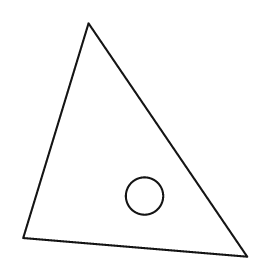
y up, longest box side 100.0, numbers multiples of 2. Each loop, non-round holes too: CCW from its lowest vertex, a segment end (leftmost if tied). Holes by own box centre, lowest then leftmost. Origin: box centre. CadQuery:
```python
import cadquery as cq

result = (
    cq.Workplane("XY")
    .moveTo(48.0, -50.0)
    .lineTo(-20.0, 50.0)
    .lineTo(-48.0, -42.0)
    .close()
    .moveTo(4.0, -24.0)
    .circle(8.0)
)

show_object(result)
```